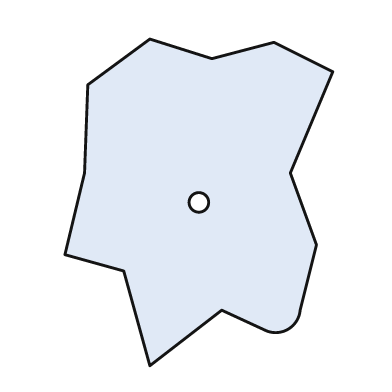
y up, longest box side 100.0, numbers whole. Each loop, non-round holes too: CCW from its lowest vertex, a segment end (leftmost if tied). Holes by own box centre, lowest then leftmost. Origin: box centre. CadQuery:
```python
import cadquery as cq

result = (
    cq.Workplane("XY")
    .moveTo(-15.0, -50.0)
    .lineTo(7.0, -33.0)
    .lineTo(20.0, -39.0)
    .threePointArc((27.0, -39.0), (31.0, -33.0))
    .lineTo(36.0, -13.0)
    .lineTo(28.0, 9.0)
    .lineTo(41.0, 40.0)
    .lineTo(23.0, 49.0)
    .lineTo(4.0, 44.0)
    .lineTo(-15.0, 50.0)
    .lineTo(-34.0, 36.0)
    .lineTo(-35.0, 9.0)
    .lineTo(-41.0, -16.0)
    .lineTo(-23.0, -21.0)
    .close()
    .moveTo(0.0, 0.0)
    .circle(3.0)
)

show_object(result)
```